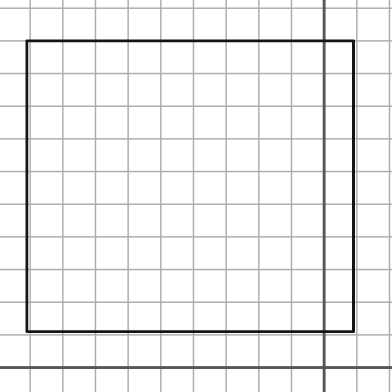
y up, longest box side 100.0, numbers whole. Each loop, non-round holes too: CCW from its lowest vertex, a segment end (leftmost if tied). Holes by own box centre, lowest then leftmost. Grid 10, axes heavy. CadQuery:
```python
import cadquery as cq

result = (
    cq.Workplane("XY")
    .moveTo(-91.0, 11.0)
    .lineTo(9.0, 11.0)
    .lineTo(9.0, 100.0)
    .lineTo(-91.0, 100.0)
    .close()
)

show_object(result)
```